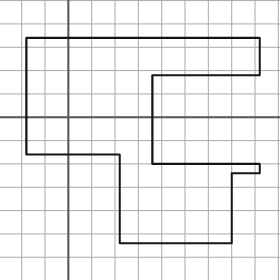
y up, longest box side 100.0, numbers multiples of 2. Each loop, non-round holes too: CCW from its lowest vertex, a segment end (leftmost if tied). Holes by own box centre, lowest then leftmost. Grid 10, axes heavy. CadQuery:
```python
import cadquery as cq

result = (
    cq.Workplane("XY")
    .moveTo(22.0, -54.0)
    .lineTo(70.0, -54.0)
    .lineTo(70.0, -24.0)
    .lineTo(82.0, -24.0)
    .lineTo(82.0, -20.0)
    .lineTo(36.0, -20.0)
    .lineTo(36.0, 18.0)
    .lineTo(82.0, 18.0)
    .lineTo(82.0, 34.0)
    .lineTo(-18.0, 34.0)
    .lineTo(-18.0, -16.0)
    .lineTo(22.0, -16.0)
    .close()
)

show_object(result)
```